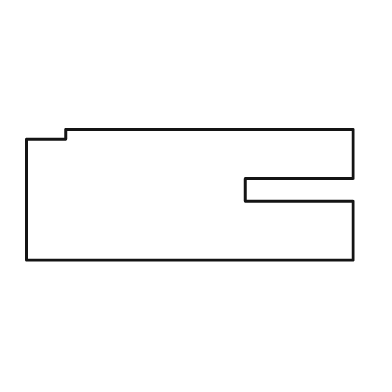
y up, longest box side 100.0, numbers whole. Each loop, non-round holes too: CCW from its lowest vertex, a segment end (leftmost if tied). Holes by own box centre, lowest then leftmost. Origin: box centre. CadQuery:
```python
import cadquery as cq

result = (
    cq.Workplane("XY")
    .moveTo(-50.0, -20.0)
    .lineTo(50.0, -20.0)
    .lineTo(50.0, -2.0)
    .lineTo(17.0, -2.0)
    .lineTo(17.0, 5.0)
    .lineTo(50.0, 5.0)
    .lineTo(50.0, 20.0)
    .lineTo(-38.0, 20.0)
    .lineTo(-38.0, 17.0)
    .lineTo(-50.0, 17.0)
    .close()
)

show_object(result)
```